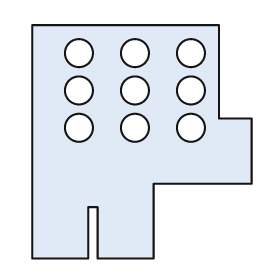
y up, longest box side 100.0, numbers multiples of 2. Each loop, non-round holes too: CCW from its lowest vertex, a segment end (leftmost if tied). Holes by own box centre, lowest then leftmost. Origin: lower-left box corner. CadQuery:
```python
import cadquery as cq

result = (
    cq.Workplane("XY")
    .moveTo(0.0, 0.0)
    .lineTo(24.0, 0.0)
    .lineTo(24.0, 22.0)
    .lineTo(28.0, 22.0)
    .lineTo(28.0, 0.0)
    .lineTo(52.0, 0.0)
    .lineTo(52.0, 32.0)
    .lineTo(94.0, 32.0)
    .lineTo(94.0, 60.0)
    .lineTo(80.0, 60.0)
    .lineTo(80.0, 100.0)
    .lineTo(0.0, 100.0)
    .close()
    .moveTo(20.0, 56.0)
    .circle(6.0)
    .moveTo(44.0, 56.0)
    .circle(6.0)
    .moveTo(68.0, 56.0)
    .circle(6.0)
    .moveTo(20.0, 72.0)
    .circle(6.0)
    .moveTo(44.0, 72.0)
    .circle(6.0)
    .moveTo(68.0, 72.0)
    .circle(6.0)
    .moveTo(20.0, 88.0)
    .circle(6.0)
    .moveTo(44.0, 88.0)
    .circle(6.0)
    .moveTo(68.0, 88.0)
    .circle(6.0)
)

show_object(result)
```